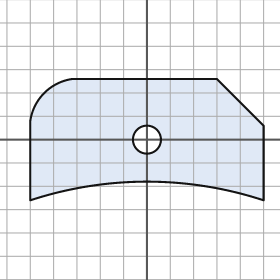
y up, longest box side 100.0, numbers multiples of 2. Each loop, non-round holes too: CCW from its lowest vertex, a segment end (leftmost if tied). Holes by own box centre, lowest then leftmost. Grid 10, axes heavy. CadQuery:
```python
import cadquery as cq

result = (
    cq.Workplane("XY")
    .moveTo(-50.0, -26.0)
    .threePointArc((0.0, -18.0), (50.0, -26.0))
    .lineTo(50.0, 6.0)
    .lineTo(30.0, 26.0)
    .lineTo(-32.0, 26.0)
    .threePointArc((-44.0, 20.0), (-50.0, 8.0))
    .close()
    .moveTo(0.0, 0.0)
    .circle(6.0)
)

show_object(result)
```